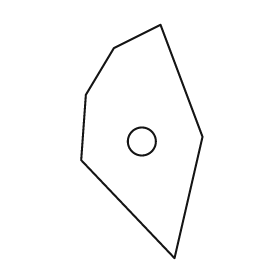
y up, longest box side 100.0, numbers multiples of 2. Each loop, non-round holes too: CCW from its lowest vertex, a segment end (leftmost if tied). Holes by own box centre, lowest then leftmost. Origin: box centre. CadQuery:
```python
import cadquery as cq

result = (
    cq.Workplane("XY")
    .moveTo(14.0, -50.0)
    .lineTo(26.0, 2.0)
    .lineTo(8.0, 50.0)
    .lineTo(-12.0, 40.0)
    .lineTo(-24.0, 20.0)
    .lineTo(-26.0, -8.0)
    .close()
    .moveTo(0.0, 0.0)
    .circle(6.0)
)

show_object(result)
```